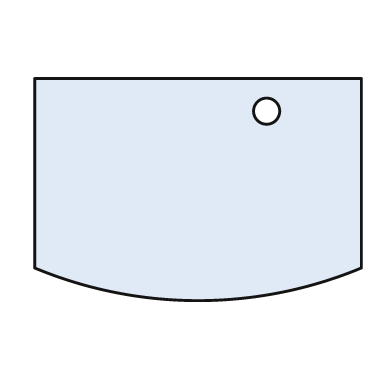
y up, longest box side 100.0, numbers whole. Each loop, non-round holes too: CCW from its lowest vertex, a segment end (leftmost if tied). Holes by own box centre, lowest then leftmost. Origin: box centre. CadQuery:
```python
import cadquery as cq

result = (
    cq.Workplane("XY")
    .moveTo(-50.0, -24.0)
    .threePointArc((0.0, -34.0), (50.0, -24.0))
    .lineTo(50.0, 34.0)
    .lineTo(-50.0, 34.0)
    .close()
    .moveTo(21.0, 24.0)
    .circle(4.0)
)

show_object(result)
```